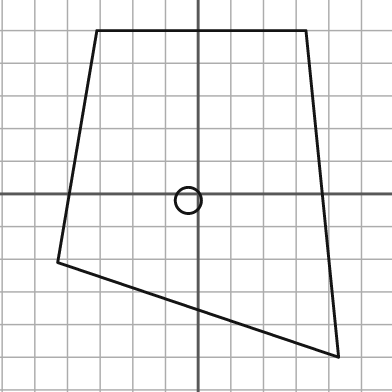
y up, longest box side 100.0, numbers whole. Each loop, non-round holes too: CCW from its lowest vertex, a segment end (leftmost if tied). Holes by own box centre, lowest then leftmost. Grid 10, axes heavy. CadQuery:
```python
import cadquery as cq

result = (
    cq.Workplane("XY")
    .moveTo(43.0, -50.0)
    .lineTo(33.0, 50.0)
    .lineTo(-31.0, 50.0)
    .lineTo(-43.0, -21.0)
    .close()
    .moveTo(-3.0, -2.0)
    .circle(4.0)
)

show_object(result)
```